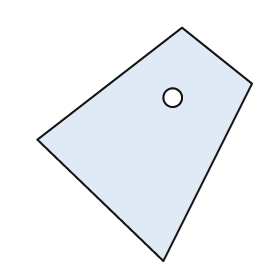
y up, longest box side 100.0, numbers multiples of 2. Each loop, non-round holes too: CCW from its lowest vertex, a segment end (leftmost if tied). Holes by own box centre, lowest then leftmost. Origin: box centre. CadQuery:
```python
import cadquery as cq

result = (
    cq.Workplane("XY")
    .moveTo(8.0, -50.0)
    .lineTo(46.0, 26.0)
    .lineTo(16.0, 50.0)
    .lineTo(-46.0, 2.0)
    .close()
    .moveTo(12.0, 20.0)
    .circle(4.0)
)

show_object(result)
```